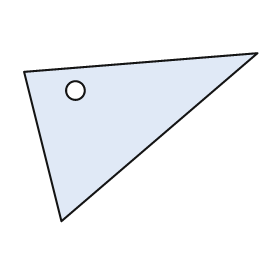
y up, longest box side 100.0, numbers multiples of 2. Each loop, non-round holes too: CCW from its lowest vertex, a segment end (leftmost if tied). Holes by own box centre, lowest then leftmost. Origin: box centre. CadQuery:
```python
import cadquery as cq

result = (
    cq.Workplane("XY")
    .moveTo(-34.0, -36.0)
    .lineTo(50.0, 36.0)
    .lineTo(-50.0, 28.0)
    .close()
    .moveTo(-28.0, 20.0)
    .circle(4.0)
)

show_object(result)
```